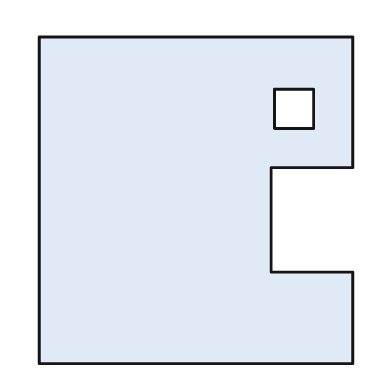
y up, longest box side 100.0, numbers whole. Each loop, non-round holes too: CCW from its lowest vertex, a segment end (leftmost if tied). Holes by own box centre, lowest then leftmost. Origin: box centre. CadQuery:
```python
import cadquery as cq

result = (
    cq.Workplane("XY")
    .moveTo(-48.0, -50.0)
    .lineTo(48.0, -50.0)
    .lineTo(48.0, -22.0)
    .lineTo(23.0, -22.0)
    .lineTo(23.0, 10.0)
    .lineTo(48.0, 10.0)
    .lineTo(48.0, 50.0)
    .lineTo(-48.0, 50.0)
    .close()
    .moveTo(24.0, 22.0)
    .lineTo(36.0, 22.0)
    .lineTo(36.0, 34.0)
    .lineTo(24.0, 34.0)
    .close()
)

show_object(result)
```